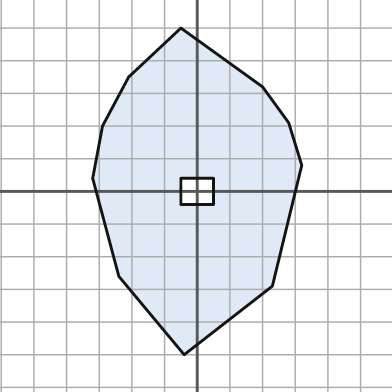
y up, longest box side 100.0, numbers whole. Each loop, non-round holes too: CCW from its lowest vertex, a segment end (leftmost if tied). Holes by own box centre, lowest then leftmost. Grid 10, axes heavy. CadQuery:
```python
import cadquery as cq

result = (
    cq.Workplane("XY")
    .moveTo(-4.0, -50.0)
    .lineTo(23.0, -29.0)
    .lineTo(32.0, 8.0)
    .lineTo(28.0, 21.0)
    .lineTo(20.0, 32.0)
    .lineTo(-5.0, 50.0)
    .lineTo(-21.0, 35.0)
    .lineTo(-29.0, 20.0)
    .lineTo(-32.0, 4.0)
    .lineTo(-24.0, -26.0)
    .close()
    .moveTo(-5.0, -4.0)
    .lineTo(5.0, -4.0)
    .lineTo(5.0, 4.0)
    .lineTo(-5.0, 4.0)
    .close()
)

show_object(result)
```